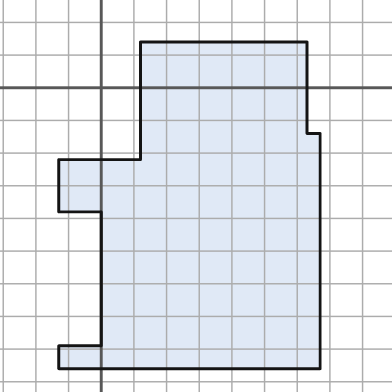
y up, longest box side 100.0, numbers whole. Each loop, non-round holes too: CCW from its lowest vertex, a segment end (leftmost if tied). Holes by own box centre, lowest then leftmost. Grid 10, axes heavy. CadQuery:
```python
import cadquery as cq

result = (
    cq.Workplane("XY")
    .moveTo(-13.0, -86.0)
    .lineTo(67.0, -86.0)
    .lineTo(67.0, -14.0)
    .lineTo(63.0, -14.0)
    .lineTo(63.0, 14.0)
    .lineTo(12.0, 14.0)
    .lineTo(12.0, -22.0)
    .lineTo(-13.0, -22.0)
    .lineTo(-13.0, -38.0)
    .lineTo(0.0, -38.0)
    .lineTo(0.0, -79.0)
    .lineTo(-13.0, -79.0)
    .close()
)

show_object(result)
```